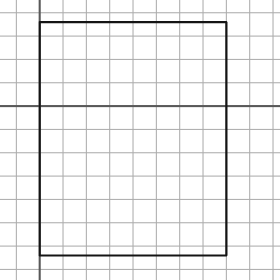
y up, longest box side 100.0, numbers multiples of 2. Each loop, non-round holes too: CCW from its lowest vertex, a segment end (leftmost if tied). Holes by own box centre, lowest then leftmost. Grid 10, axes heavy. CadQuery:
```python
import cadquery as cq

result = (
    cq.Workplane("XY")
    .moveTo(0.0, -64.0)
    .lineTo(80.0, -64.0)
    .lineTo(80.0, 36.0)
    .lineTo(0.0, 36.0)
    .close()
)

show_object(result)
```